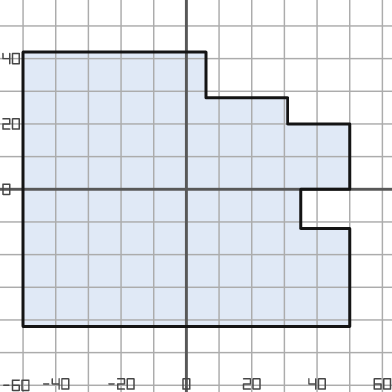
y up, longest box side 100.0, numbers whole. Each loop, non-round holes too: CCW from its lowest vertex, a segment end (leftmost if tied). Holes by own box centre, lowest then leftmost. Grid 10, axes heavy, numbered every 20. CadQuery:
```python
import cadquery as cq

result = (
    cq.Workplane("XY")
    .moveTo(-50.0, -42.0)
    .lineTo(50.0, -42.0)
    .lineTo(50.0, -12.0)
    .lineTo(35.0, -12.0)
    .lineTo(35.0, 0.0)
    .lineTo(50.0, 0.0)
    .lineTo(50.0, 20.0)
    .lineTo(31.0, 20.0)
    .lineTo(31.0, 28.0)
    .lineTo(6.0, 28.0)
    .lineTo(6.0, 42.0)
    .lineTo(-50.0, 42.0)
    .close()
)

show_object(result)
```